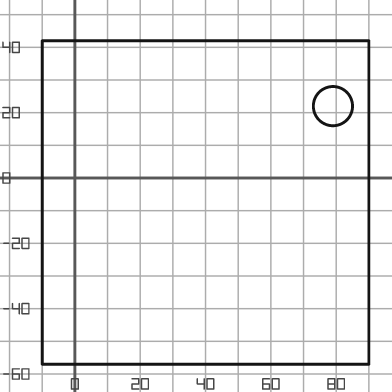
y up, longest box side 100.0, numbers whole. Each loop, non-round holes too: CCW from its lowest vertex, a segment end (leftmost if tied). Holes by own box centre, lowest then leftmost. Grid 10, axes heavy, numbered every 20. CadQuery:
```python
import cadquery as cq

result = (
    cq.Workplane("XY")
    .moveTo(-10.0, -57.0)
    .lineTo(90.0, -57.0)
    .lineTo(90.0, 42.0)
    .lineTo(-10.0, 42.0)
    .close()
    .moveTo(79.0, 22.0)
    .circle(6.0)
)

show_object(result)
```